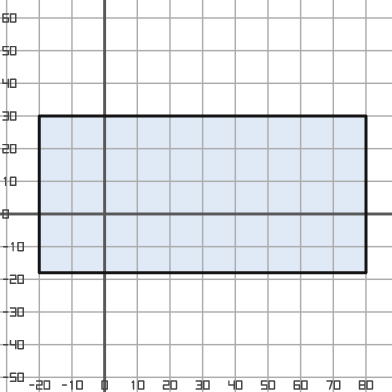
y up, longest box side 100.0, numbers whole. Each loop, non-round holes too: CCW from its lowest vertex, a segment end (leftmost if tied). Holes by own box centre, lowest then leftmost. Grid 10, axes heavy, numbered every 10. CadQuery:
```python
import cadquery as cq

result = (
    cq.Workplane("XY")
    .moveTo(-20.0, -18.0)
    .lineTo(80.0, -18.0)
    .lineTo(80.0, 30.0)
    .lineTo(-20.0, 30.0)
    .close()
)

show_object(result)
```